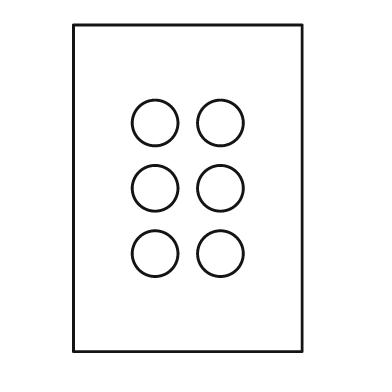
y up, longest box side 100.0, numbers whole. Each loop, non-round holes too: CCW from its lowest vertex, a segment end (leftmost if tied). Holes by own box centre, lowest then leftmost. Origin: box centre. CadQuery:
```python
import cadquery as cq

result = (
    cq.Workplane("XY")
    .moveTo(-35.0, -50.0)
    .lineTo(35.0, -50.0)
    .lineTo(35.0, 50.0)
    .lineTo(-35.0, 50.0)
    .close()
    .moveTo(-10.0, -20.0)
    .circle(7.0)
    .moveTo(10.0, -20.0)
    .circle(7.0)
    .moveTo(-10.0, 0.0)
    .circle(7.0)
    .moveTo(10.0, 0.0)
    .circle(7.0)
    .moveTo(-10.0, 20.0)
    .circle(7.0)
    .moveTo(10.0, 20.0)
    .circle(7.0)
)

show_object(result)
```